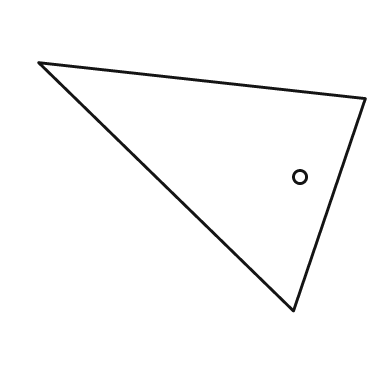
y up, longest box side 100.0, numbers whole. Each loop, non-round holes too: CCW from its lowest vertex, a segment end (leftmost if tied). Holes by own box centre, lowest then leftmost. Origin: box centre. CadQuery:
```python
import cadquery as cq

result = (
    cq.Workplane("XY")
    .moveTo(28.0, -38.0)
    .lineTo(50.0, 27.0)
    .lineTo(-50.0, 38.0)
    .close()
    .moveTo(30.0, 3.0)
    .circle(2.0)
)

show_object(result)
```